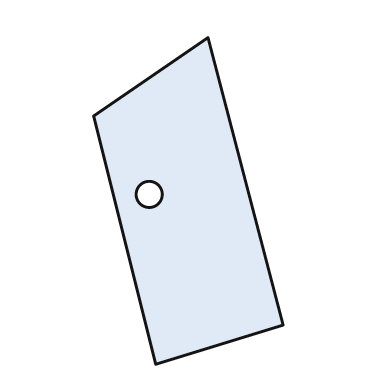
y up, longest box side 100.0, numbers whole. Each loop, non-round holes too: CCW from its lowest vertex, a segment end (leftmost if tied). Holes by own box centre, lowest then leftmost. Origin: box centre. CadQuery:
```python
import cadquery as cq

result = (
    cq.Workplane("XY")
    .moveTo(-10.0, -50.0)
    .lineTo(29.0, -38.0)
    .lineTo(6.0, 50.0)
    .lineTo(-29.0, 26.0)
    .close()
    .moveTo(-12.0, 2.0)
    .circle(4.0)
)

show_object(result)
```